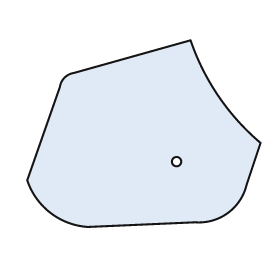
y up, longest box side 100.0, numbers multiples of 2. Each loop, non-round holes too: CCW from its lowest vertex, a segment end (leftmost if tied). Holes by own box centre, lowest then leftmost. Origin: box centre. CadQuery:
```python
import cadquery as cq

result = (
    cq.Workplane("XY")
    .moveTo(-24.0, -40.0)
    .lineTo(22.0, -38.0)
    .threePointArc((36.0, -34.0), (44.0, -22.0))
    .lineTo(50.0, -4.0)
    .threePointArc((32.0, 16.0), (20.0, 40.0))
    .lineTo(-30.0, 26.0)
    .threePointArc((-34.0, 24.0), (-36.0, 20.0))
    .lineTo(-50.0, -20.0)
    .threePointArc((-40.0, -34.0), (-24.0, -40.0))
    .close()
    .moveTo(14.0, -12.0)
    .circle(2.0)
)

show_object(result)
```